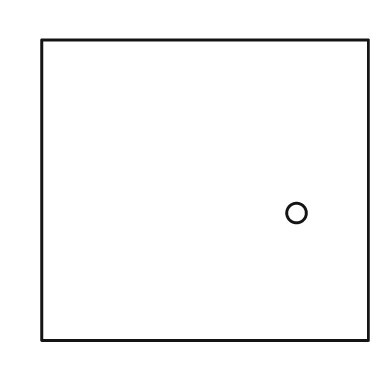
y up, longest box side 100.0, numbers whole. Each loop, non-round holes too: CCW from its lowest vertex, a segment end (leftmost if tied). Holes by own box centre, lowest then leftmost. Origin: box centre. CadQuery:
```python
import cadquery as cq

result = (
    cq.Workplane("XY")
    .moveTo(-50.0, -46.0)
    .lineTo(50.0, -46.0)
    .lineTo(50.0, 46.0)
    .lineTo(-50.0, 46.0)
    .close()
    .moveTo(28.0, -7.0)
    .circle(3.0)
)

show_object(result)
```